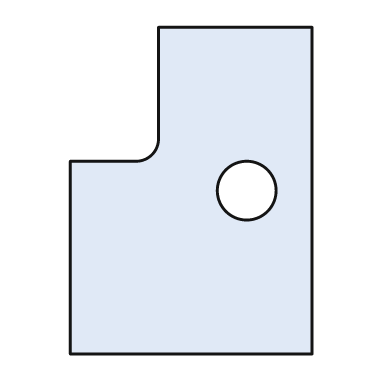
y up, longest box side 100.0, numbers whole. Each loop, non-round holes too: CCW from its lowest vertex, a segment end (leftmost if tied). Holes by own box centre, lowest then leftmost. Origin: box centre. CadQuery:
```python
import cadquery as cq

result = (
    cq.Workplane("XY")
    .moveTo(-37.0, -50.0)
    .lineTo(37.0, -50.0)
    .lineTo(37.0, 50.0)
    .lineTo(-10.0, 50.0)
    .lineTo(-10.0, 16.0)
    .threePointArc((-12.0, 11.0), (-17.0, 9.0))
    .lineTo(-37.0, 9.0)
    .close()
    .moveTo(17.0, 0.0)
    .circle(9.0)
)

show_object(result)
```